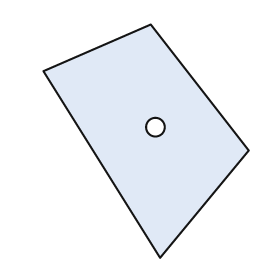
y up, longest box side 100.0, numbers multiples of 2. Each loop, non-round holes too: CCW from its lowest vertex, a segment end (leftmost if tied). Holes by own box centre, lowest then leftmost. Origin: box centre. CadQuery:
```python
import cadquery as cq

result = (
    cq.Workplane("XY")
    .moveTo(6.0, -50.0)
    .lineTo(44.0, -4.0)
    .lineTo(2.0, 50.0)
    .lineTo(-44.0, 30.0)
    .close()
    .moveTo(4.0, 6.0)
    .circle(4.0)
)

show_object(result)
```